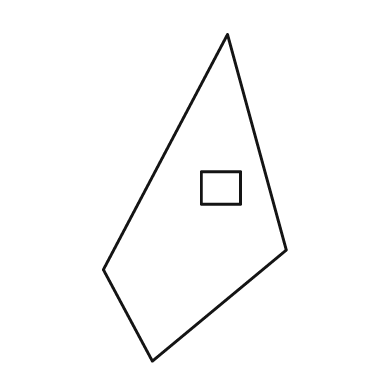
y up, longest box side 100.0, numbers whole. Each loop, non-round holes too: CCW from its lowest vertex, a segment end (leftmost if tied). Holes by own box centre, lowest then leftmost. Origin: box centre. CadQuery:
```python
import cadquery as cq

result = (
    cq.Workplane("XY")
    .moveTo(-13.0, -50.0)
    .lineTo(28.0, -16.0)
    .lineTo(10.0, 50.0)
    .lineTo(-28.0, -22.0)
    .close()
    .moveTo(2.0, -2.0)
    .lineTo(14.0, -2.0)
    .lineTo(14.0, 8.0)
    .lineTo(2.0, 8.0)
    .close()
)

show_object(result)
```